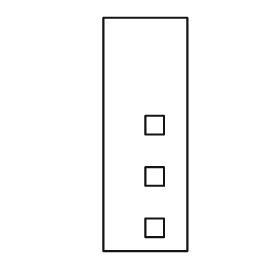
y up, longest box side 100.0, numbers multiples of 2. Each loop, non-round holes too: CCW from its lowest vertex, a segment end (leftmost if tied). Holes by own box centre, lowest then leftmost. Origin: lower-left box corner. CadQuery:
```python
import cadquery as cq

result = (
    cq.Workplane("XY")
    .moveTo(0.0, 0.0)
    .lineTo(36.0, 0.0)
    .lineTo(36.0, 100.0)
    .lineTo(0.0, 100.0)
    .close()
    .moveTo(18.0, 6.0)
    .lineTo(26.0, 6.0)
    .lineTo(26.0, 14.0)
    .lineTo(18.0, 14.0)
    .close()
    .moveTo(18.0, 28.0)
    .lineTo(26.0, 28.0)
    .lineTo(26.0, 36.0)
    .lineTo(18.0, 36.0)
    .close()
    .moveTo(18.0, 50.0)
    .lineTo(26.0, 50.0)
    .lineTo(26.0, 58.0)
    .lineTo(18.0, 58.0)
    .close()
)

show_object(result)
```